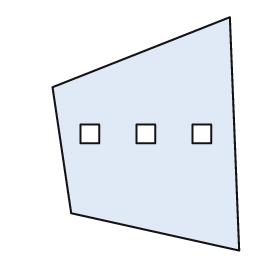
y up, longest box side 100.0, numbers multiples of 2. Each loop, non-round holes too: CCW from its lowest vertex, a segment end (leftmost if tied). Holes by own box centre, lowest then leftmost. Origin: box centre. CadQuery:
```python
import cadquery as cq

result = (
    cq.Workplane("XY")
    .moveTo(40.0, -50.0)
    .lineTo(36.0, 50.0)
    .lineTo(-40.0, 20.0)
    .lineTo(-32.0, -34.0)
    .close()
    .moveTo(-28.0, -4.0)
    .lineTo(-20.0, -4.0)
    .lineTo(-20.0, 4.0)
    .lineTo(-28.0, 4.0)
    .close()
    .moveTo(-4.0, -4.0)
    .lineTo(4.0, -4.0)
    .lineTo(4.0, 4.0)
    .lineTo(-4.0, 4.0)
    .close()
    .moveTo(20.0, -4.0)
    .lineTo(28.0, -4.0)
    .lineTo(28.0, 4.0)
    .lineTo(20.0, 4.0)
    .close()
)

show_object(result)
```